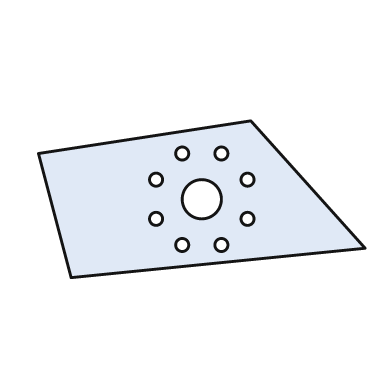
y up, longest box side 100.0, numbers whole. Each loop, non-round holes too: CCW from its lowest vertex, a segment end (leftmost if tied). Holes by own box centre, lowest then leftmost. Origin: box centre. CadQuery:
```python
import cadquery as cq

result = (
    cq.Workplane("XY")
    .moveTo(-40.0, -24.0)
    .lineTo(50.0, -15.0)
    .lineTo(15.0, 24.0)
    .lineTo(-50.0, 14.0)
    .close()
    .moveTo(-6.0, -14.0)
    .circle(2.0)
    .moveTo(6.0, -14.0)
    .circle(2.0)
    .moveTo(-14.0, -6.0)
    .circle(2.0)
    .moveTo(14.0, -6.0)
    .circle(2.0)
    .moveTo(0.0, 0.0)
    .circle(6.0)
    .moveTo(-14.0, 6.0)
    .circle(2.0)
    .moveTo(14.0, 6.0)
    .circle(2.0)
    .moveTo(-6.0, 14.0)
    .circle(2.0)
    .moveTo(6.0, 14.0)
    .circle(2.0)
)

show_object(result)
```